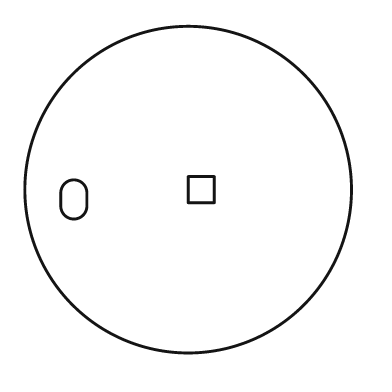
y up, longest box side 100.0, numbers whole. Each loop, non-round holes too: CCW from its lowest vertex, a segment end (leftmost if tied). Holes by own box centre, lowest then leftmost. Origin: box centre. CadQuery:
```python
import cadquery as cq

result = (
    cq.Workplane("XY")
    .moveTo(0.0, 0.0)
    .circle(50.0)
    .moveTo(-39.0, -5.0)
    .threePointArc((-35.0, -9.0), (-31.0, -5.0))
    .lineTo(-31.0, -1.0)
    .threePointArc((-35.0, 3.0), (-39.0, -1.0))
    .close()
    .moveTo(0.0, -4.0)
    .lineTo(8.0, -4.0)
    .lineTo(8.0, 4.0)
    .lineTo(0.0, 4.0)
    .close()
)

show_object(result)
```